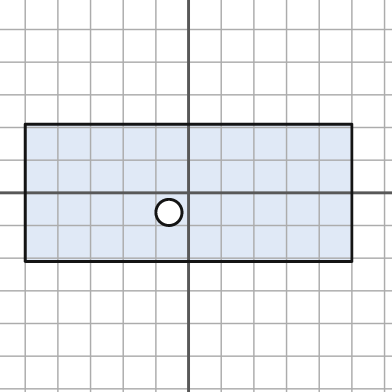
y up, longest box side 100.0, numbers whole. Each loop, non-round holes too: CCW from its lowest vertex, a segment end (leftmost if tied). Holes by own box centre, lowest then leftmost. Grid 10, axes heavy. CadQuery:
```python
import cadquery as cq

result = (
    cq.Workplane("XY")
    .moveTo(-50.0, -21.0)
    .lineTo(50.0, -21.0)
    .lineTo(50.0, 21.0)
    .lineTo(-50.0, 21.0)
    .close()
    .moveTo(-6.0, -6.0)
    .circle(4.0)
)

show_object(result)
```